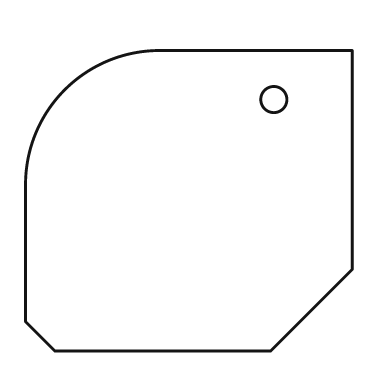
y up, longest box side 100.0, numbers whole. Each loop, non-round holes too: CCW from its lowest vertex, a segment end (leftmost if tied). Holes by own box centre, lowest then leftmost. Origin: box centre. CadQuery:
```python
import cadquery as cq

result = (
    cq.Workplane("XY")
    .moveTo(-41.0, -46.0)
    .lineTo(25.0, -46.0)
    .lineTo(50.0, -21.0)
    .lineTo(50.0, 46.0)
    .lineTo(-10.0, 46.0)
    .threePointArc((-38.0, 34.0), (-50.0, 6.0))
    .lineTo(-50.0, -37.0)
    .close()
    .moveTo(26.0, 31.0)
    .circle(4.0)
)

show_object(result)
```